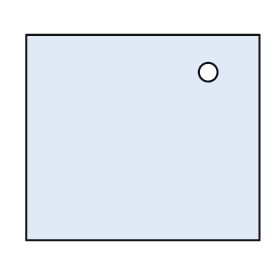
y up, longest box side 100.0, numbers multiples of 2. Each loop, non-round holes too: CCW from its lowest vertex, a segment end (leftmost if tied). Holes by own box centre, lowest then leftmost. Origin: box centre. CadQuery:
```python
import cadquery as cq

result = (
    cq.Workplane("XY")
    .moveTo(-50.0, -44.0)
    .lineTo(50.0, -44.0)
    .lineTo(50.0, 44.0)
    .lineTo(-50.0, 44.0)
    .close()
    .moveTo(28.0, 28.0)
    .circle(4.0)
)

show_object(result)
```